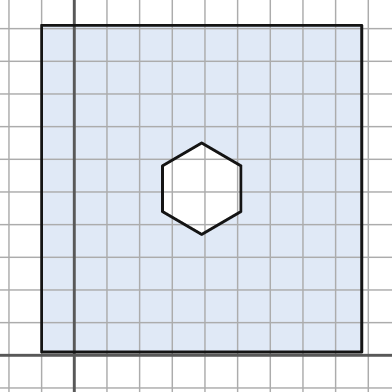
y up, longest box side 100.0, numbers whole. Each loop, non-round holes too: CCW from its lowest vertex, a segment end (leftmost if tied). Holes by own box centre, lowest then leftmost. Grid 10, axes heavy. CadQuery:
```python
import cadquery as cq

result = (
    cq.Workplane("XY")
    .moveTo(-10.0, 1.0)
    .lineTo(88.0, 1.0)
    .lineTo(88.0, 101.0)
    .lineTo(-10.0, 101.0)
    .close()
    .moveTo(39.0, 37.0)
    .lineTo(51.0, 44.0)
    .lineTo(51.0, 58.0)
    .lineTo(39.0, 65.0)
    .lineTo(27.0, 58.0)
    .lineTo(27.0, 44.0)
    .close()
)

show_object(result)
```